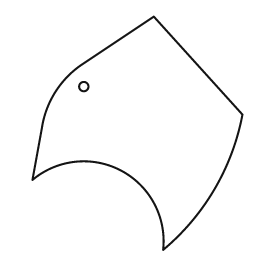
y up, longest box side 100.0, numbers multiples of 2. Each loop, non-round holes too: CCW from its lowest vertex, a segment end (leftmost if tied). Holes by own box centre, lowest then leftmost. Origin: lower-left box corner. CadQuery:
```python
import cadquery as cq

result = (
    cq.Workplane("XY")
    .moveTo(56.0, 0.0)
    .threePointArc((78.0, 26.0), (90.0, 58.0))
    .lineTo(52.0, 100.0)
    .lineTo(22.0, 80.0)
    .threePointArc((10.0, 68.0), (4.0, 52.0))
    .lineTo(0.0, 30.0)
    .threePointArc((38.0, 34.0), (56.0, 0.0))
    .close()
    .moveTo(22.0, 70.0)
    .circle(2.0)
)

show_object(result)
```